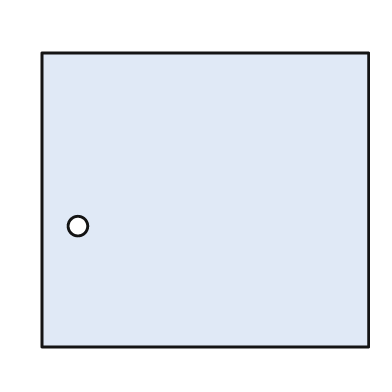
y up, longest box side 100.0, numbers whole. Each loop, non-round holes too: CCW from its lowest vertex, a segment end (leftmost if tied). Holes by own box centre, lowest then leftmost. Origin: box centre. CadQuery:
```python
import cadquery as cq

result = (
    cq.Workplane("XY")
    .moveTo(-50.0, -45.0)
    .lineTo(50.0, -45.0)
    .lineTo(50.0, 45.0)
    .lineTo(-50.0, 45.0)
    .close()
    .moveTo(-39.0, -8.0)
    .circle(3.0)
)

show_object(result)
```